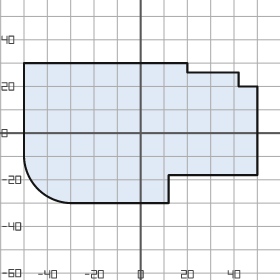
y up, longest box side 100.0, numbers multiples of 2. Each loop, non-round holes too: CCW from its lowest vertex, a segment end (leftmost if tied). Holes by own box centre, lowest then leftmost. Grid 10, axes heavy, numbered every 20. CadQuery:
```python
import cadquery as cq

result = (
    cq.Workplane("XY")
    .moveTo(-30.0, -30.0)
    .lineTo(12.0, -30.0)
    .lineTo(12.0, -18.0)
    .lineTo(50.0, -18.0)
    .lineTo(50.0, 20.0)
    .lineTo(42.0, 20.0)
    .lineTo(42.0, 26.0)
    .lineTo(20.0, 26.0)
    .lineTo(20.0, 30.0)
    .lineTo(-50.0, 30.0)
    .lineTo(-50.0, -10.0)
    .threePointArc((-44.0, -24.0), (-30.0, -30.0))
    .close()
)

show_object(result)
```